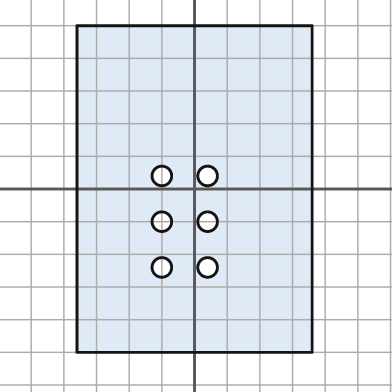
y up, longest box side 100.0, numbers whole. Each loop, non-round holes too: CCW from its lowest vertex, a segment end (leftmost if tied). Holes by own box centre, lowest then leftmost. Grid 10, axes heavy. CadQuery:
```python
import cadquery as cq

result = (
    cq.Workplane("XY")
    .moveTo(-36.0, -50.0)
    .lineTo(36.0, -50.0)
    .lineTo(36.0, 50.0)
    .lineTo(-36.0, 50.0)
    .close()
    .moveTo(-10.0, -24.0)
    .circle(3.0)
    .moveTo(4.0, -24.0)
    .circle(3.0)
    .moveTo(-10.0, -10.0)
    .circle(3.0)
    .moveTo(4.0, -10.0)
    .circle(3.0)
    .moveTo(-10.0, 4.0)
    .circle(3.0)
    .moveTo(4.0, 4.0)
    .circle(3.0)
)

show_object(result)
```